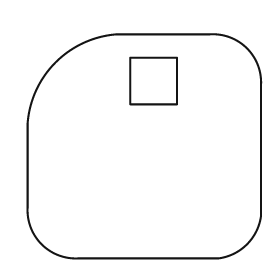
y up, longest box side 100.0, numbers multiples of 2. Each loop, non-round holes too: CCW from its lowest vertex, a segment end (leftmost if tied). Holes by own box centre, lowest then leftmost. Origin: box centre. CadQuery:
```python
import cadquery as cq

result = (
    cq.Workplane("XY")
    .moveTo(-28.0, -48.0)
    .lineTo(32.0, -48.0)
    .threePointArc((44.0, -42.0), (50.0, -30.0))
    .lineTo(50.0, 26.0)
    .threePointArc((44.0, 42.0), (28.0, 48.0))
    .lineTo(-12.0, 48.0)
    .threePointArc((-38.0, 36.0), (-50.0, 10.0))
    .lineTo(-50.0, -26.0)
    .threePointArc((-44.0, -42.0), (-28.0, -48.0))
    .close()
    .moveTo(-6.0, 18.0)
    .lineTo(14.0, 18.0)
    .lineTo(14.0, 38.0)
    .lineTo(-6.0, 38.0)
    .close()
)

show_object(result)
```